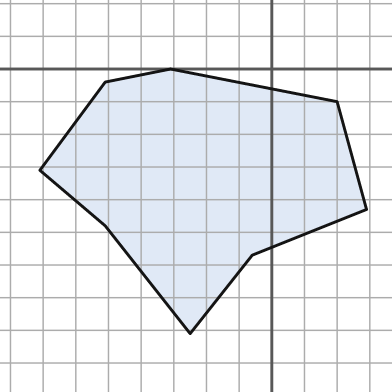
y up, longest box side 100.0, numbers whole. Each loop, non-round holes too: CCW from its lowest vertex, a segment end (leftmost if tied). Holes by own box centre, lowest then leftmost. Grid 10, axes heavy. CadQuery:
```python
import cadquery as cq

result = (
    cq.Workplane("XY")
    .moveTo(-25.0, -81.0)
    .lineTo(-6.0, -57.0)
    .lineTo(29.0, -43.0)
    .lineTo(20.0, -10.0)
    .lineTo(-31.0, 0.0)
    .lineTo(-51.0, -4.0)
    .lineTo(-71.0, -31.0)
    .lineTo(-51.0, -48.0)
    .close()
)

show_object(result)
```